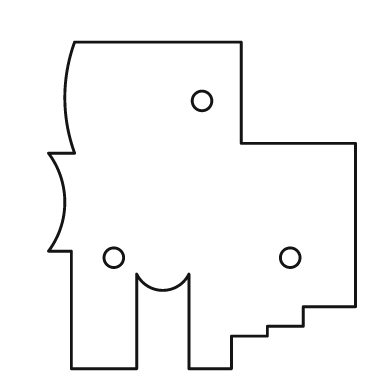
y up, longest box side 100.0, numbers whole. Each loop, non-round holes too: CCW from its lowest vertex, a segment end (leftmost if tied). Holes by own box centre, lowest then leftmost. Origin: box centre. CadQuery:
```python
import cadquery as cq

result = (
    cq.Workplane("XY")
    .moveTo(-40.0, -50.0)
    .lineTo(-20.0, -50.0)
    .lineTo(-20.0, -21.0)
    .threePointArc((-12.0, -26.0), (-4.0, -21.0))
    .lineTo(-4.0, -50.0)
    .lineTo(9.0, -50.0)
    .lineTo(9.0, -40.0)
    .lineTo(20.0, -40.0)
    .lineTo(20.0, -37.0)
    .lineTo(31.0, -37.0)
    .lineTo(31.0, -31.0)
    .lineTo(47.0, -31.0)
    .lineTo(47.0, 19.0)
    .lineTo(12.0, 19.0)
    .lineTo(12.0, 50.0)
    .lineTo(-39.0, 50.0)
    .threePointArc((-42.0, 33.0), (-39.0, 16.0))
    .lineTo(-47.0, 16.0)
    .threePointArc((-42.0, 1.0), (-47.0, -14.0))
    .lineTo(-40.0, -14.0)
    .close()
    .moveTo(-27.0, -16.0)
    .circle(3.0)
    .moveTo(27.0, -16.0)
    .circle(3.0)
    .moveTo(0.0, 32.0)
    .circle(3.0)
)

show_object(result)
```